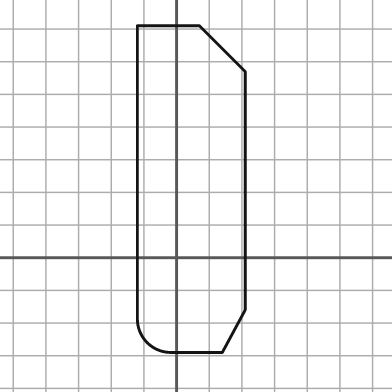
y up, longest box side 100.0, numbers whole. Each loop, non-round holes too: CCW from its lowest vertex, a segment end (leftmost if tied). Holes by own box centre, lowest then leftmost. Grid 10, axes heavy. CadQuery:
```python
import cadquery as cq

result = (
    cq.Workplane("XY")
    .moveTo(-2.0, -29.0)
    .lineTo(14.0, -29.0)
    .lineTo(21.0, -16.0)
    .lineTo(21.0, 57.0)
    .lineTo(7.0, 71.0)
    .lineTo(-12.0, 71.0)
    .lineTo(-12.0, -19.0)
    .threePointArc((-9.0, -26.0), (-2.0, -29.0))
    .close()
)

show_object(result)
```